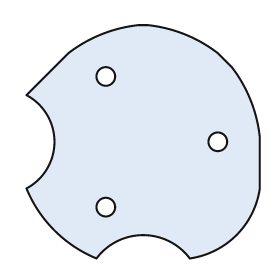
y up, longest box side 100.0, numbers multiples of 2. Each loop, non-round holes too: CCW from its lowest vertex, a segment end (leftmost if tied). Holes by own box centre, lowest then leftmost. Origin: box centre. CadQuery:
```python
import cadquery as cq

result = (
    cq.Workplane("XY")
    .moveTo(-20.0, -50.0)
    .threePointArc((0.0, -40.0), (20.0, -50.0))
    .threePointArc((40.0, -40.0), (50.0, -20.0))
    .lineTo(50.0, 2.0)
    .threePointArc((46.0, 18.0), (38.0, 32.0))
    .lineTo(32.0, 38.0)
    .threePointArc((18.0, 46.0), (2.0, 50.0))
    .lineTo(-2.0, 50.0)
    .threePointArc((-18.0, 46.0), (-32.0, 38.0))
    .lineTo(-50.0, 20.0)
    .threePointArc((-38.0, 0.0), (-50.0, -20.0))
    .threePointArc((-38.0, -38.0), (-20.0, -50.0))
    .close()
    .moveTo(-16.0, -28.0)
    .circle(4.0)
    .moveTo(32.0, 0.0)
    .circle(4.0)
    .moveTo(-16.0, 28.0)
    .circle(4.0)
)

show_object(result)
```